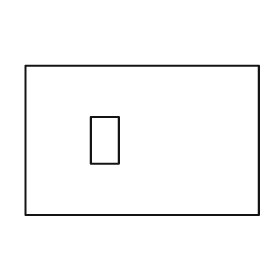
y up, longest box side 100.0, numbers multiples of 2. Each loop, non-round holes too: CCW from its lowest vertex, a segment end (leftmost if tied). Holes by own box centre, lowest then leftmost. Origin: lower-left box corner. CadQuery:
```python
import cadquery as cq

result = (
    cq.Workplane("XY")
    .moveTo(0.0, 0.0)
    .lineTo(100.0, 0.0)
    .lineTo(100.0, 64.0)
    .lineTo(0.0, 64.0)
    .close()
    .moveTo(28.0, 22.0)
    .lineTo(40.0, 22.0)
    .lineTo(40.0, 42.0)
    .lineTo(28.0, 42.0)
    .close()
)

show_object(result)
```